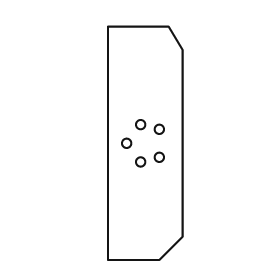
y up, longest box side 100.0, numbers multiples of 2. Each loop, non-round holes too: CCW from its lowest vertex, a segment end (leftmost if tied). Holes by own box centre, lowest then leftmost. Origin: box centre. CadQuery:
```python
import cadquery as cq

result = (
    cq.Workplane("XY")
    .moveTo(-16.0, -50.0)
    .lineTo(6.0, -50.0)
    .lineTo(16.0, -40.0)
    .lineTo(16.0, 40.0)
    .lineTo(10.0, 50.0)
    .lineTo(-16.0, 50.0)
    .close()
    .moveTo(-2.0, -8.0)
    .circle(2.0)
    .moveTo(6.0, -6.0)
    .circle(2.0)
    .moveTo(-8.0, 0.0)
    .circle(2.0)
    .moveTo(6.0, 6.0)
    .circle(2.0)
    .moveTo(-2.0, 8.0)
    .circle(2.0)
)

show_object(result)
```